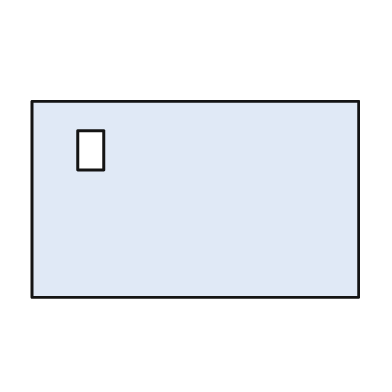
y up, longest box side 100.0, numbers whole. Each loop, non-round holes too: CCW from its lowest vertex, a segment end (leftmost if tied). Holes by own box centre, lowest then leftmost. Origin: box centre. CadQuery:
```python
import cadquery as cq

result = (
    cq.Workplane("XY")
    .moveTo(-50.0, -30.0)
    .lineTo(50.0, -30.0)
    .lineTo(50.0, 30.0)
    .lineTo(-50.0, 30.0)
    .close()
    .moveTo(-36.0, 9.0)
    .lineTo(-28.0, 9.0)
    .lineTo(-28.0, 21.0)
    .lineTo(-36.0, 21.0)
    .close()
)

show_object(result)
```